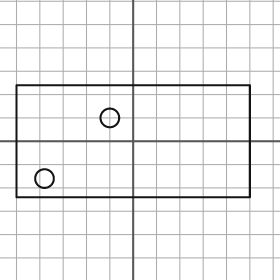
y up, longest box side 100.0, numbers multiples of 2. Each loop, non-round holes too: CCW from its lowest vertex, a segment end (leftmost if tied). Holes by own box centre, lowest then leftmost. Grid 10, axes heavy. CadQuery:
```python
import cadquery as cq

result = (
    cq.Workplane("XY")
    .moveTo(-50.0, -24.0)
    .lineTo(50.0, -24.0)
    .lineTo(50.0, 24.0)
    .lineTo(-50.0, 24.0)
    .close()
    .moveTo(-38.0, -16.0)
    .circle(4.0)
    .moveTo(-10.0, 10.0)
    .circle(4.0)
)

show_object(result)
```